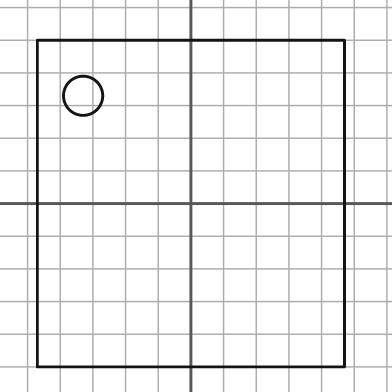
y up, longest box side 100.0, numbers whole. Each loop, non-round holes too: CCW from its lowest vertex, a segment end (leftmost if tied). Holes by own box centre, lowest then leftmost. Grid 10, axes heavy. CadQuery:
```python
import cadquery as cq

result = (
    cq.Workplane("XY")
    .moveTo(-47.0, -50.0)
    .lineTo(47.0, -50.0)
    .lineTo(47.0, 50.0)
    .lineTo(-47.0, 50.0)
    .close()
    .moveTo(-33.0, 33.0)
    .circle(6.0)
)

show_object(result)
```